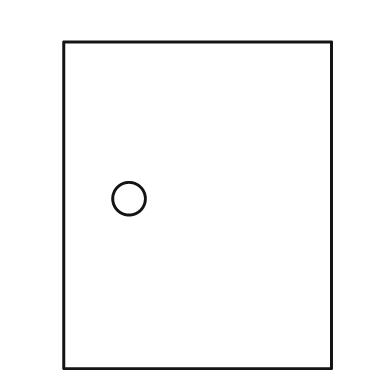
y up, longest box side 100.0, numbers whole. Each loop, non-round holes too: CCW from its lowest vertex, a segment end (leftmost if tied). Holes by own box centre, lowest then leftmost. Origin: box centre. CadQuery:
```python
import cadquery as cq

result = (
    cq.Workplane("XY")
    .moveTo(-41.0, -50.0)
    .lineTo(41.0, -50.0)
    .lineTo(41.0, 50.0)
    .lineTo(-41.0, 50.0)
    .close()
    .moveTo(-21.0, 2.0)
    .circle(5.0)
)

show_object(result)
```